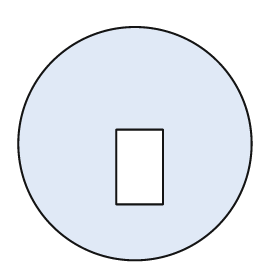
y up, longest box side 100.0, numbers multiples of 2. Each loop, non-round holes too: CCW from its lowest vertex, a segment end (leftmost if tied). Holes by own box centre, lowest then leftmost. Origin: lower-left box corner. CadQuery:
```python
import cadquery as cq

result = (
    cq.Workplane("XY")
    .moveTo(50.0, 50.0)
    .circle(50.0)
    .moveTo(42.0, 24.0)
    .lineTo(62.0, 24.0)
    .lineTo(62.0, 56.0)
    .lineTo(42.0, 56.0)
    .close()
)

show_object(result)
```